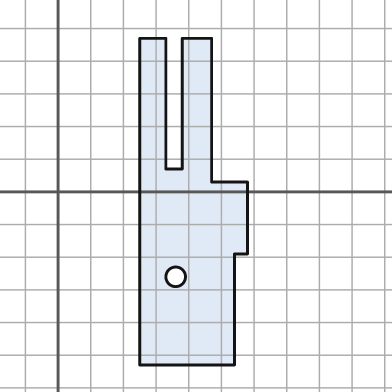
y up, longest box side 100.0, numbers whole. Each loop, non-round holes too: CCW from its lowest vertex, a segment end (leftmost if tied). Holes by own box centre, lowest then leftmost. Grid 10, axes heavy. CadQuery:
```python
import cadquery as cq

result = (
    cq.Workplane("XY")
    .moveTo(25.0, -53.0)
    .lineTo(54.0, -53.0)
    .lineTo(54.0, -19.0)
    .lineTo(58.0, -19.0)
    .lineTo(58.0, 3.0)
    .lineTo(47.0, 3.0)
    .lineTo(47.0, 47.0)
    .lineTo(38.0, 47.0)
    .lineTo(38.0, 7.0)
    .lineTo(33.0, 7.0)
    .lineTo(33.0, 47.0)
    .lineTo(25.0, 47.0)
    .close()
    .moveTo(36.0, -26.0)
    .circle(3.0)
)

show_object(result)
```